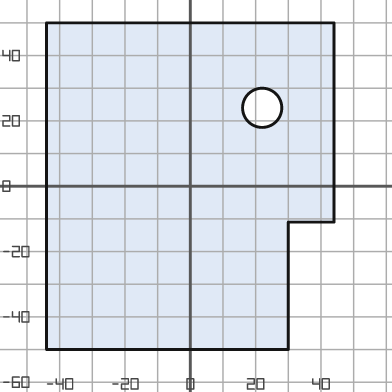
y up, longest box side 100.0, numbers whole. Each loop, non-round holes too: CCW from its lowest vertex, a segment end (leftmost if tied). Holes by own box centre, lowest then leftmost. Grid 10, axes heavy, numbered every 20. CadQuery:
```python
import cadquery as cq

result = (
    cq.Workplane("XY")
    .moveTo(-44.0, -50.0)
    .lineTo(30.0, -50.0)
    .lineTo(30.0, -11.0)
    .lineTo(44.0, -11.0)
    .lineTo(44.0, 50.0)
    .lineTo(-44.0, 50.0)
    .close()
    .moveTo(22.0, 24.0)
    .circle(6.0)
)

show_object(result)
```